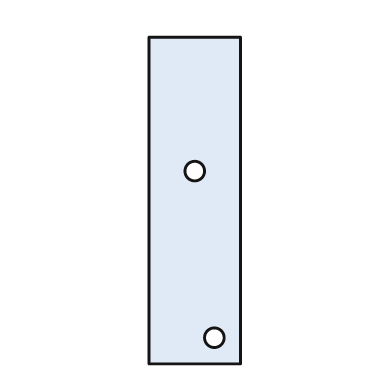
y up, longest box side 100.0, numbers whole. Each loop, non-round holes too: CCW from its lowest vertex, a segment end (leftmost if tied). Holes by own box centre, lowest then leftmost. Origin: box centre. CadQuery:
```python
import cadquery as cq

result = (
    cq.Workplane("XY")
    .moveTo(-14.0, -50.0)
    .lineTo(14.0, -50.0)
    .lineTo(14.0, 50.0)
    .lineTo(-14.0, 50.0)
    .close()
    .moveTo(6.0, -42.0)
    .circle(3.0)
    .moveTo(0.0, 9.0)
    .circle(3.0)
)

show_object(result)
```